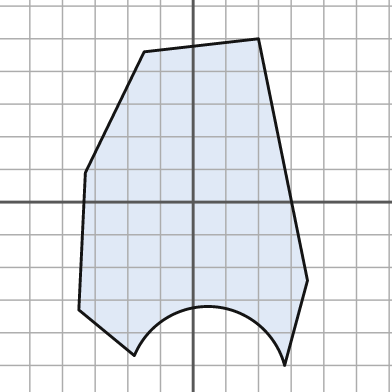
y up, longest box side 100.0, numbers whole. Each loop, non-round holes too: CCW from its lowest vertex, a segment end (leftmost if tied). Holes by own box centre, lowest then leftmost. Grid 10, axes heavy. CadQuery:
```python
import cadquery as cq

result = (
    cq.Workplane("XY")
    .moveTo(28.0, -50.0)
    .lineTo(35.0, -24.0)
    .lineTo(20.0, 50.0)
    .lineTo(-15.0, 46.0)
    .lineTo(-33.0, 9.0)
    .lineTo(-35.0, -33.0)
    .lineTo(-18.0, -47.0)
    .threePointArc((6.0, -32.0), (28.0, -50.0))
    .close()
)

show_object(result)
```